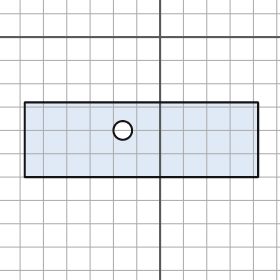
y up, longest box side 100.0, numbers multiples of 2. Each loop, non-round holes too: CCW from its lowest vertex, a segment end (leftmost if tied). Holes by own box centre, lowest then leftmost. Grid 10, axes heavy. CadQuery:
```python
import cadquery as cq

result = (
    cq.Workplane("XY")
    .moveTo(-58.0, -60.0)
    .lineTo(42.0, -60.0)
    .lineTo(42.0, -28.0)
    .lineTo(-58.0, -28.0)
    .close()
    .moveTo(-16.0, -40.0)
    .circle(4.0)
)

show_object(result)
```